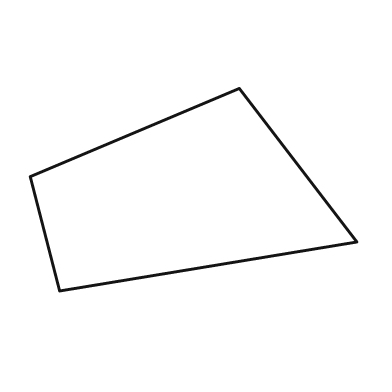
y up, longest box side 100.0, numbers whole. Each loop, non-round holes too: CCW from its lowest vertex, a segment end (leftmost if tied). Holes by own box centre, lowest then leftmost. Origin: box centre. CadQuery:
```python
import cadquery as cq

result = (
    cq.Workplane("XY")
    .moveTo(-41.0, -31.0)
    .lineTo(50.0, -16.0)
    .lineTo(14.0, 31.0)
    .lineTo(-50.0, 4.0)
    .close()
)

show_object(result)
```